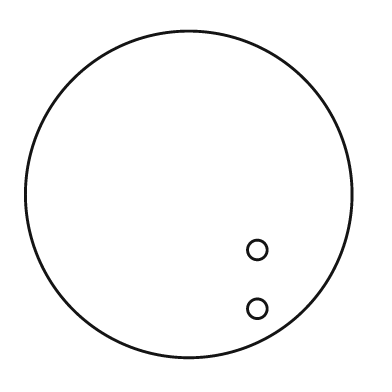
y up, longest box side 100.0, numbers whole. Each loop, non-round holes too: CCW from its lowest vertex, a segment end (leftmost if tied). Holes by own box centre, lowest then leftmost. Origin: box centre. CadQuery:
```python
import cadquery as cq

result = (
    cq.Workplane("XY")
    .moveTo(0.0, 0.0)
    .circle(50.0)
    .moveTo(21.0, -35.0)
    .circle(3.0)
    .moveTo(21.0, -17.0)
    .circle(3.0)
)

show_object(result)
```